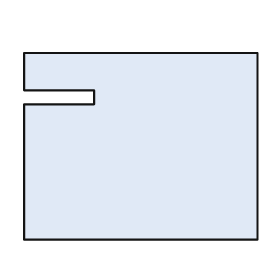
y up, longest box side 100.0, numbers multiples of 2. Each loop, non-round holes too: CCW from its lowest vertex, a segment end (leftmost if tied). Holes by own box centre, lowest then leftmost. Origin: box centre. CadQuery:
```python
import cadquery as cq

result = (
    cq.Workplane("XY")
    .moveTo(-50.0, -40.0)
    .lineTo(50.0, -40.0)
    .lineTo(50.0, 40.0)
    .lineTo(-50.0, 40.0)
    .lineTo(-50.0, 24.0)
    .lineTo(-20.0, 24.0)
    .lineTo(-20.0, 18.0)
    .lineTo(-50.0, 18.0)
    .close()
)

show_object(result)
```